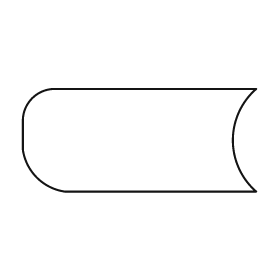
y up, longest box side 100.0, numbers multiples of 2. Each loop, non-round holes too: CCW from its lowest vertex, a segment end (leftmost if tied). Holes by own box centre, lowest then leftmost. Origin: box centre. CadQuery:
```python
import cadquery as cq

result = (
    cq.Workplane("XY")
    .moveTo(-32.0, -22.0)
    .lineTo(50.0, -22.0)
    .threePointArc((40.0, 0.0), (50.0, 22.0))
    .lineTo(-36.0, 22.0)
    .threePointArc((-46.0, 18.0), (-50.0, 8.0))
    .lineTo(-50.0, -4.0)
    .threePointArc((-44.0, -16.0), (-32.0, -22.0))
    .close()
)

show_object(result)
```